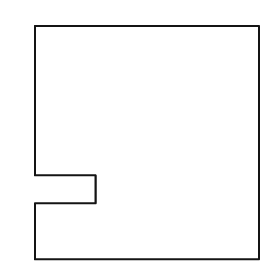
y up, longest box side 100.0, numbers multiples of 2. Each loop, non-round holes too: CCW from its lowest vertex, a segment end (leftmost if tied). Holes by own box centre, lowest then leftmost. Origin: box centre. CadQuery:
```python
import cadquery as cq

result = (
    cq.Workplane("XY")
    .moveTo(-48.0, -50.0)
    .lineTo(48.0, -50.0)
    .lineTo(48.0, 50.0)
    .lineTo(-48.0, 50.0)
    .lineTo(-48.0, -14.0)
    .lineTo(-22.0, -14.0)
    .lineTo(-22.0, -26.0)
    .lineTo(-48.0, -26.0)
    .close()
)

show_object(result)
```